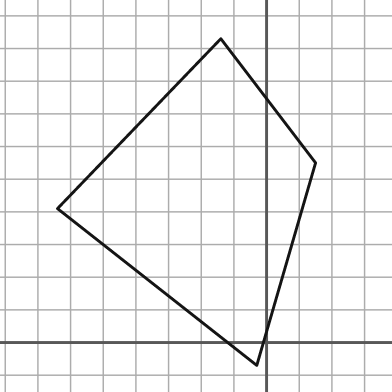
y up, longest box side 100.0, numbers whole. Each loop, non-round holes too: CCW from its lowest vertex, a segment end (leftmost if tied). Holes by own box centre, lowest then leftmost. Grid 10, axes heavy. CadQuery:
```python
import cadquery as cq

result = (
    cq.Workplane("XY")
    .moveTo(-3.0, -7.0)
    .lineTo(15.0, 55.0)
    .lineTo(-14.0, 93.0)
    .lineTo(-64.0, 41.0)
    .close()
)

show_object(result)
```